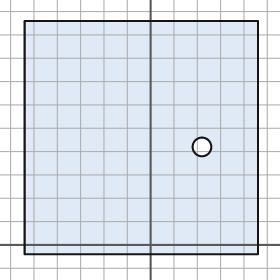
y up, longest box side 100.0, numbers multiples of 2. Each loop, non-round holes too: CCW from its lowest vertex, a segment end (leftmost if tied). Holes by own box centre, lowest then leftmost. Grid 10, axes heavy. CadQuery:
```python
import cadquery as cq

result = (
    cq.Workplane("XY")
    .moveTo(-54.0, -4.0)
    .lineTo(46.0, -4.0)
    .lineTo(46.0, 96.0)
    .lineTo(-54.0, 96.0)
    .close()
    .moveTo(22.0, 42.0)
    .circle(4.0)
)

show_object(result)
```